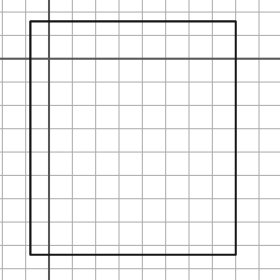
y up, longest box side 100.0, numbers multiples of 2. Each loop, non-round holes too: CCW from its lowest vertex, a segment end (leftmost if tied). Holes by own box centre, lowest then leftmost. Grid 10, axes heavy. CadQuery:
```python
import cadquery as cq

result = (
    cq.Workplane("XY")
    .moveTo(-8.0, -84.0)
    .lineTo(80.0, -84.0)
    .lineTo(80.0, 16.0)
    .lineTo(-8.0, 16.0)
    .close()
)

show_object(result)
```